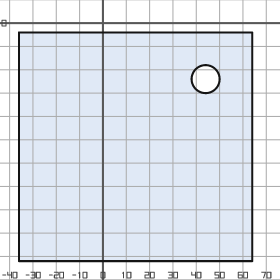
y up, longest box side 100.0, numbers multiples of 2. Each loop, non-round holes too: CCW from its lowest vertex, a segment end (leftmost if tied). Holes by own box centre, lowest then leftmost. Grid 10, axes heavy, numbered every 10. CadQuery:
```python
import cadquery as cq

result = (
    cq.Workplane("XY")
    .moveTo(-36.0, -102.0)
    .lineTo(64.0, -102.0)
    .lineTo(64.0, -4.0)
    .lineTo(-36.0, -4.0)
    .close()
    .moveTo(44.0, -24.0)
    .circle(6.0)
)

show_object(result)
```